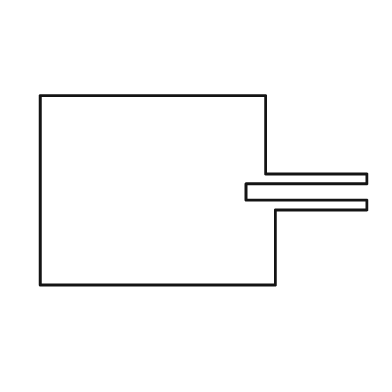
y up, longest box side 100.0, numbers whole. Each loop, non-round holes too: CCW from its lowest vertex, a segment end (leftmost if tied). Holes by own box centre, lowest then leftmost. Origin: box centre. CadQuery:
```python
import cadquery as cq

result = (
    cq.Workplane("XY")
    .moveTo(-50.0, -29.0)
    .lineTo(22.0, -29.0)
    .lineTo(22.0, -6.0)
    .lineTo(50.0, -6.0)
    .lineTo(50.0, -3.0)
    .lineTo(13.0, -3.0)
    .lineTo(13.0, 2.0)
    .lineTo(50.0, 2.0)
    .lineTo(50.0, 5.0)
    .lineTo(19.0, 5.0)
    .lineTo(19.0, 29.0)
    .lineTo(-50.0, 29.0)
    .close()
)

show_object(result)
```